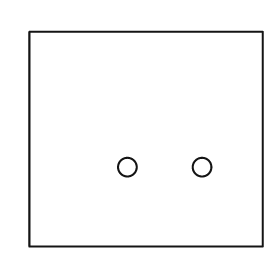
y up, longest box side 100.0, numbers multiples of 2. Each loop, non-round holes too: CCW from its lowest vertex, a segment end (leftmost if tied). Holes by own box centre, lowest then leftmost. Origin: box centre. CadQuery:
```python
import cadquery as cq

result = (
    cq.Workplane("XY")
    .moveTo(-50.0, -46.0)
    .lineTo(50.0, -46.0)
    .lineTo(50.0, 46.0)
    .lineTo(-50.0, 46.0)
    .close()
    .moveTo(-8.0, -12.0)
    .circle(4.0)
    .moveTo(24.0, -12.0)
    .circle(4.0)
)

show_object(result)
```